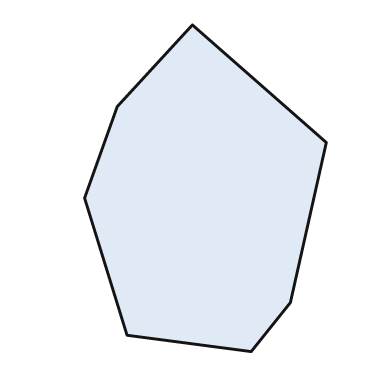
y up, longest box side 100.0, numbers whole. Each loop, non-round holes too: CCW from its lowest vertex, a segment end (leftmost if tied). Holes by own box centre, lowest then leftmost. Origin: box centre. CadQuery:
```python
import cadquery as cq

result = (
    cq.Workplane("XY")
    .moveTo(14.0, -50.0)
    .lineTo(26.0, -35.0)
    .lineTo(37.0, 14.0)
    .lineTo(-4.0, 50.0)
    .lineTo(-27.0, 25.0)
    .lineTo(-37.0, -3.0)
    .lineTo(-24.0, -45.0)
    .close()
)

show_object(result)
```